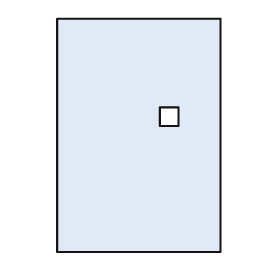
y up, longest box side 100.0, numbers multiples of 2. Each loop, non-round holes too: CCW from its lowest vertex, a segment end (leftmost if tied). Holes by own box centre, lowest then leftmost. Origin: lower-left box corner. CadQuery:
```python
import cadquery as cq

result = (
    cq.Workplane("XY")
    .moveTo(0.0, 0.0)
    .lineTo(70.0, 0.0)
    .lineTo(70.0, 100.0)
    .lineTo(0.0, 100.0)
    .close()
    .moveTo(44.0, 54.0)
    .lineTo(52.0, 54.0)
    .lineTo(52.0, 62.0)
    .lineTo(44.0, 62.0)
    .close()
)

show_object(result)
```